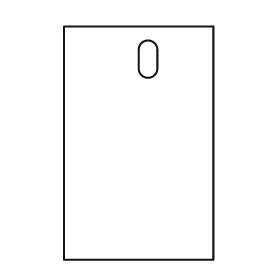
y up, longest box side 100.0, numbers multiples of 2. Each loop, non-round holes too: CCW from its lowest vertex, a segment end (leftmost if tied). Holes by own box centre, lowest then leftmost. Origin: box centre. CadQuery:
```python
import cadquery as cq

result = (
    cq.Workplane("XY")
    .moveTo(-32.0, -50.0)
    .lineTo(32.0, -50.0)
    .lineTo(32.0, 50.0)
    .lineTo(-32.0, 50.0)
    .close()
    .moveTo(0.0, 32.0)
    .threePointArc((4.0, 28.0), (8.0, 32.0))
    .lineTo(8.0, 40.0)
    .threePointArc((4.0, 44.0), (0.0, 40.0))
    .close()
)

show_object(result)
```